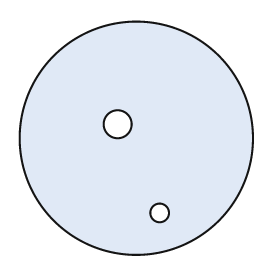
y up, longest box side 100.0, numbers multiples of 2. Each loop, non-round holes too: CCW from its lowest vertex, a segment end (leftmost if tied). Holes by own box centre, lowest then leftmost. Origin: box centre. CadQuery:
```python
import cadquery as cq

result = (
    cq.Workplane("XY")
    .moveTo(0.0, 0.0)
    .circle(50.0)
    .moveTo(10.0, -32.0)
    .circle(4.0)
    .moveTo(-8.0, 6.0)
    .circle(6.0)
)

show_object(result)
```